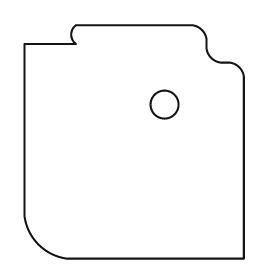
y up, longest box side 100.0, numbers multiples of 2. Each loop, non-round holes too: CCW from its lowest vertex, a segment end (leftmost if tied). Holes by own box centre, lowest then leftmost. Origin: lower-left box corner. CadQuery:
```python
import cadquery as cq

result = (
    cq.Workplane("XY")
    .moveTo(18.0, 0.0)
    .lineTo(94.0, 0.0)
    .lineTo(94.0, 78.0)
    .threePointArc((92.0, 82.0), (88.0, 84.0))
    .lineTo(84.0, 84.0)
    .threePointArc((80.0, 86.0), (78.0, 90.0))
    .lineTo(78.0, 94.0)
    .threePointArc((76.0, 98.0), (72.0, 100.0))
    .lineTo(22.0, 100.0)
    .threePointArc((20.0, 96.0), (22.0, 92.0))
    .lineTo(0.0, 92.0)
    .lineTo(0.0, 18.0)
    .threePointArc((6.0, 6.0), (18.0, 0.0))
    .close()
    .moveTo(60.0, 66.0)
    .circle(6.0)
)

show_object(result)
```